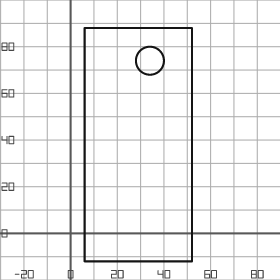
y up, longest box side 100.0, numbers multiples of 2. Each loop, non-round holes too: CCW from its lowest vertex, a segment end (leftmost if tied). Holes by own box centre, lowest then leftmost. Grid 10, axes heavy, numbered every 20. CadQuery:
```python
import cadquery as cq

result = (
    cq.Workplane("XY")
    .moveTo(6.0, -12.0)
    .lineTo(52.0, -12.0)
    .lineTo(52.0, 88.0)
    .lineTo(6.0, 88.0)
    .close()
    .moveTo(34.0, 74.0)
    .circle(6.0)
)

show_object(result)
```